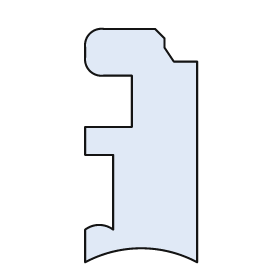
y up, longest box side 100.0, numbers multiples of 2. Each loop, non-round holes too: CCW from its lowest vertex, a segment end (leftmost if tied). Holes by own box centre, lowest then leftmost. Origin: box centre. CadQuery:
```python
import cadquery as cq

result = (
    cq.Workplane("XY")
    .moveTo(-24.0, -50.0)
    .threePointArc((0.0, -44.0), (24.0, -50.0))
    .lineTo(24.0, 36.0)
    .lineTo(14.0, 36.0)
    .lineTo(10.0, 42.0)
    .lineTo(10.0, 46.0)
    .lineTo(6.0, 50.0)
    .lineTo(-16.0, 50.0)
    .threePointArc((-22.0, 48.0), (-24.0, 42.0))
    .lineTo(-24.0, 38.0)
    .threePointArc((-22.0, 32.0), (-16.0, 30.0))
    .lineTo(-4.0, 30.0)
    .lineTo(-4.0, 8.0)
    .lineTo(-24.0, 8.0)
    .lineTo(-24.0, -4.0)
    .lineTo(-12.0, -4.0)
    .lineTo(-12.0, -36.0)
    .threePointArc((-18.0, -34.0), (-24.0, -36.0))
    .close()
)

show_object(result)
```